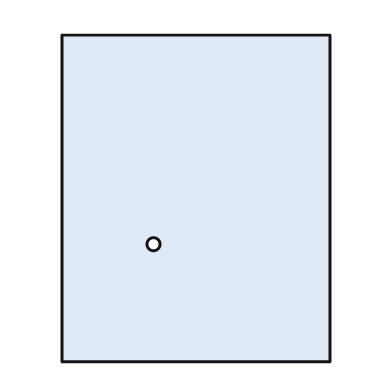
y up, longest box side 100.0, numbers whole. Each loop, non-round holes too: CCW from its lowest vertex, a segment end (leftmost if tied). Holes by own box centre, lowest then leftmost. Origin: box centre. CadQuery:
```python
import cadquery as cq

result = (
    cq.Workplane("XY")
    .moveTo(-41.0, -50.0)
    .lineTo(41.0, -50.0)
    .lineTo(41.0, 50.0)
    .lineTo(-41.0, 50.0)
    .close()
    .moveTo(-13.0, -14.0)
    .circle(2.0)
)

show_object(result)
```